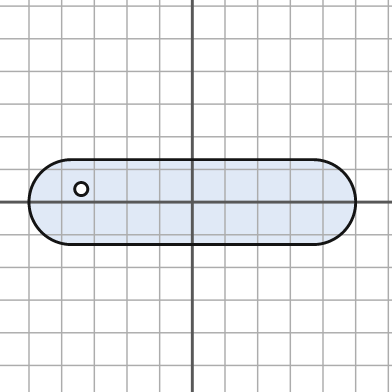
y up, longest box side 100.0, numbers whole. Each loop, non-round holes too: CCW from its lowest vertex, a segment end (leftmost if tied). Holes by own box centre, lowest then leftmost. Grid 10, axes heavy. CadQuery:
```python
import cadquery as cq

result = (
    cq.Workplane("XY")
    .moveTo(-37.0, -13.0)
    .lineTo(37.0, -13.0)
    .threePointArc((50.0, 0.0), (37.0, 13.0))
    .lineTo(-37.0, 13.0)
    .threePointArc((-50.0, 0.0), (-37.0, -13.0))
    .close()
    .moveTo(-34.0, 4.0)
    .circle(2.0)
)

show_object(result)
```